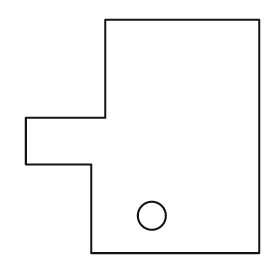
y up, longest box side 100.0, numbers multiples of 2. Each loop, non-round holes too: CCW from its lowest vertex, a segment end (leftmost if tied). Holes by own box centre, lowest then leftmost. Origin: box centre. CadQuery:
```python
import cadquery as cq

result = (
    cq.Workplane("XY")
    .moveTo(-22.0, -50.0)
    .lineTo(50.0, -50.0)
    .lineTo(50.0, 50.0)
    .lineTo(-16.0, 50.0)
    .lineTo(-16.0, 8.0)
    .lineTo(-50.0, 8.0)
    .lineTo(-50.0, -12.0)
    .lineTo(-22.0, -12.0)
    .close()
    .moveTo(4.0, -34.0)
    .circle(6.0)
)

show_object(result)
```